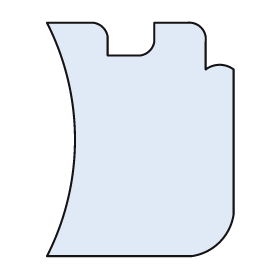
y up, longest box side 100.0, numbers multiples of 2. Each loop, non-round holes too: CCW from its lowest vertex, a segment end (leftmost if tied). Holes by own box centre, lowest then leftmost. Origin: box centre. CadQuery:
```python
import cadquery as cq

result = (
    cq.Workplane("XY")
    .moveTo(-40.0, -50.0)
    .lineTo(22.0, -50.0)
    .threePointArc((34.0, -44.0), (40.0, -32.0))
    .lineTo(40.0, 30.0)
    .threePointArc((34.0, 32.0), (28.0, 30.0))
    .lineTo(28.0, 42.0)
    .threePointArc((26.0, 48.0), (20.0, 50.0))
    .lineTo(6.0, 50.0)
    .lineTo(6.0, 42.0)
    .threePointArc((4.0, 38.0), (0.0, 36.0))
    .lineTo(-14.0, 36.0)
    .lineTo(-14.0, 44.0)
    .threePointArc((-16.0, 48.0), (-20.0, 50.0))
    .lineTo(-40.0, 50.0)
    .threePointArc((-28.0, 0.0), (-40.0, -50.0))
    .close()
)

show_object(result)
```